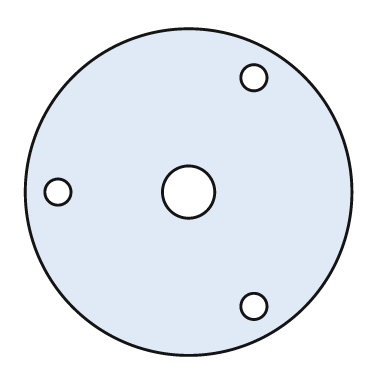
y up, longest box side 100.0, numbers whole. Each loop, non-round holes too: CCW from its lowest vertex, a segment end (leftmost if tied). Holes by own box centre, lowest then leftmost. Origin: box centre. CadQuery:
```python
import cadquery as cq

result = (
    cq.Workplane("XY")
    .moveTo(0.0, 0.0)
    .circle(50.0)
    .moveTo(20.0, -35.0)
    .circle(4.0)
    .moveTo(-40.0, 0.0)
    .circle(4.0)
    .moveTo(0.0, 0.0)
    .circle(8.0)
    .moveTo(20.0, 35.0)
    .circle(4.0)
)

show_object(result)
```